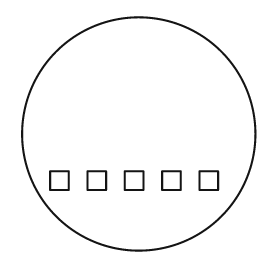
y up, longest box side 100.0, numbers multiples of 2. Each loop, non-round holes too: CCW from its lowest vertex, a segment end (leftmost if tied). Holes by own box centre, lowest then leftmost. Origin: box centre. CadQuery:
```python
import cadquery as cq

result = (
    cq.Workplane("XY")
    .moveTo(0.0, 0.0)
    .circle(50.0)
    .moveTo(-38.0, -24.0)
    .lineTo(-30.0, -24.0)
    .lineTo(-30.0, -16.0)
    .lineTo(-38.0, -16.0)
    .close()
    .moveTo(-22.0, -24.0)
    .lineTo(-14.0, -24.0)
    .lineTo(-14.0, -16.0)
    .lineTo(-22.0, -16.0)
    .close()
    .moveTo(-6.0, -24.0)
    .lineTo(2.0, -24.0)
    .lineTo(2.0, -16.0)
    .lineTo(-6.0, -16.0)
    .close()
    .moveTo(10.0, -24.0)
    .lineTo(18.0, -24.0)
    .lineTo(18.0, -16.0)
    .lineTo(10.0, -16.0)
    .close()
    .moveTo(26.0, -24.0)
    .lineTo(34.0, -24.0)
    .lineTo(34.0, -16.0)
    .lineTo(26.0, -16.0)
    .close()
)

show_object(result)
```